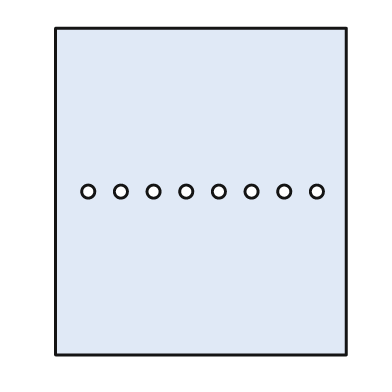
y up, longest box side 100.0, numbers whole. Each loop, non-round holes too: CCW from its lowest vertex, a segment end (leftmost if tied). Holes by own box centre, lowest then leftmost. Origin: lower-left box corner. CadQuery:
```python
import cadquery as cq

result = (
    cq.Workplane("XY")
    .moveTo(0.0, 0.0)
    .lineTo(89.0, 0.0)
    .lineTo(89.0, 100.0)
    .lineTo(0.0, 100.0)
    .close()
    .moveTo(10.0, 50.0)
    .circle(2.0)
    .moveTo(20.0, 50.0)
    .circle(2.0)
    .moveTo(30.0, 50.0)
    .circle(2.0)
    .moveTo(40.0, 50.0)
    .circle(2.0)
    .moveTo(50.0, 50.0)
    .circle(2.0)
    .moveTo(60.0, 50.0)
    .circle(2.0)
    .moveTo(70.0, 50.0)
    .circle(2.0)
    .moveTo(80.0, 50.0)
    .circle(2.0)
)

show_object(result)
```